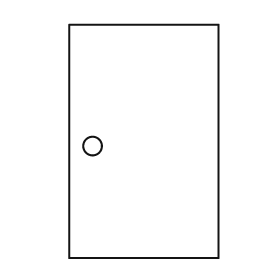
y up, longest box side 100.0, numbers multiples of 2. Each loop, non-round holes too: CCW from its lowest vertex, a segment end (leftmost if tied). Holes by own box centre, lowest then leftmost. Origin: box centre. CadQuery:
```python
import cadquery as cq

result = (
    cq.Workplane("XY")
    .moveTo(-32.0, -50.0)
    .lineTo(32.0, -50.0)
    .lineTo(32.0, 50.0)
    .lineTo(-32.0, 50.0)
    .close()
    .moveTo(-22.0, -2.0)
    .circle(4.0)
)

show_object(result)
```